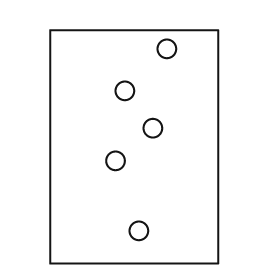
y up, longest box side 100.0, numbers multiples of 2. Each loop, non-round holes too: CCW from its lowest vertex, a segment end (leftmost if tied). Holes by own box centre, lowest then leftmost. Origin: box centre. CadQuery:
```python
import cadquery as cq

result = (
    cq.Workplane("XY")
    .moveTo(-36.0, -50.0)
    .lineTo(36.0, -50.0)
    .lineTo(36.0, 50.0)
    .lineTo(-36.0, 50.0)
    .close()
    .moveTo(2.0, -36.0)
    .circle(4.0)
    .moveTo(-8.0, -6.0)
    .circle(4.0)
    .moveTo(8.0, 8.0)
    .circle(4.0)
    .moveTo(-4.0, 24.0)
    .circle(4.0)
    .moveTo(14.0, 42.0)
    .circle(4.0)
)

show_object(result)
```